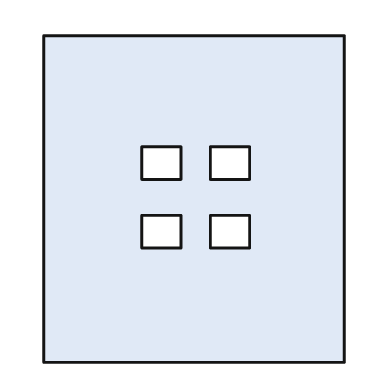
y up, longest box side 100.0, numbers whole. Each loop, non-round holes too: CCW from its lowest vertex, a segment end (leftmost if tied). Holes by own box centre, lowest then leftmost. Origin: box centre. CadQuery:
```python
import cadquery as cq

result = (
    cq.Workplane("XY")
    .moveTo(-46.0, -50.0)
    .lineTo(46.0, -50.0)
    .lineTo(46.0, 50.0)
    .lineTo(-46.0, 50.0)
    .close()
    .moveTo(-16.0, -15.0)
    .lineTo(-4.0, -15.0)
    .lineTo(-4.0, -5.0)
    .lineTo(-16.0, -5.0)
    .close()
    .moveTo(5.0, -15.0)
    .lineTo(17.0, -15.0)
    .lineTo(17.0, -5.0)
    .lineTo(5.0, -5.0)
    .close()
    .moveTo(-16.0, 6.0)
    .lineTo(-4.0, 6.0)
    .lineTo(-4.0, 16.0)
    .lineTo(-16.0, 16.0)
    .close()
    .moveTo(5.0, 6.0)
    .lineTo(17.0, 6.0)
    .lineTo(17.0, 16.0)
    .lineTo(5.0, 16.0)
    .close()
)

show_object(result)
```